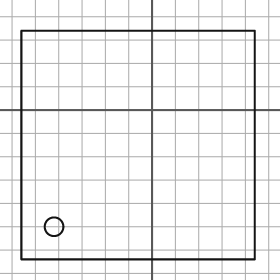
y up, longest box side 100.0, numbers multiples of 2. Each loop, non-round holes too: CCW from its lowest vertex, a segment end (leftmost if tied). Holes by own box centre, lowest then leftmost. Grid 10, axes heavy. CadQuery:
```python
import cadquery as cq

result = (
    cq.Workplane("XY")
    .moveTo(-56.0, -64.0)
    .lineTo(44.0, -64.0)
    .lineTo(44.0, 34.0)
    .lineTo(-56.0, 34.0)
    .close()
    .moveTo(-42.0, -50.0)
    .circle(4.0)
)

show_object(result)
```